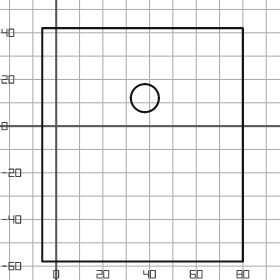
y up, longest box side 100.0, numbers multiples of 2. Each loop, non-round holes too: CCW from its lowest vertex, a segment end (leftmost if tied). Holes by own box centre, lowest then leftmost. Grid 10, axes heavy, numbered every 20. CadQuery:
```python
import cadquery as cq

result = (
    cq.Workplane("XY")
    .moveTo(-6.0, -58.0)
    .lineTo(80.0, -58.0)
    .lineTo(80.0, 42.0)
    .lineTo(-6.0, 42.0)
    .close()
    .moveTo(38.0, 12.0)
    .circle(6.0)
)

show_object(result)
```